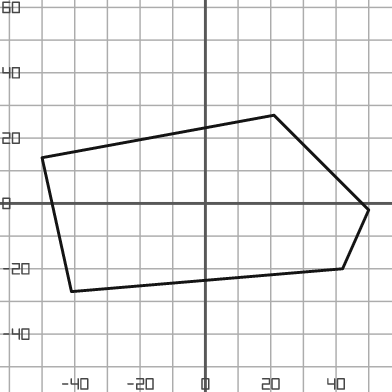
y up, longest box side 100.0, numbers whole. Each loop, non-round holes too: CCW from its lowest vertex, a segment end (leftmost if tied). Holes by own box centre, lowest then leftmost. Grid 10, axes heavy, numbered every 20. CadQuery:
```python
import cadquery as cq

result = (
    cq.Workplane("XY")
    .moveTo(-41.0, -27.0)
    .lineTo(42.0, -20.0)
    .lineTo(50.0, -2.0)
    .lineTo(21.0, 27.0)
    .lineTo(-50.0, 14.0)
    .close()
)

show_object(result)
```